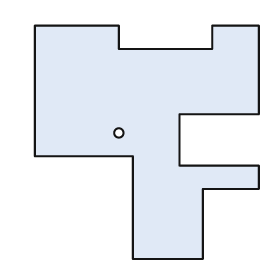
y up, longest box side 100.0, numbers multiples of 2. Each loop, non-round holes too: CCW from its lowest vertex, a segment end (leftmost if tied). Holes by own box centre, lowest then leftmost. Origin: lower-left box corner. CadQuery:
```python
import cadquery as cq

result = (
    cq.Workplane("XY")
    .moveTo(42.0, 0.0)
    .lineTo(72.0, 0.0)
    .lineTo(72.0, 30.0)
    .lineTo(96.0, 30.0)
    .lineTo(96.0, 40.0)
    .lineTo(62.0, 40.0)
    .lineTo(62.0, 62.0)
    .lineTo(96.0, 62.0)
    .lineTo(96.0, 100.0)
    .lineTo(76.0, 100.0)
    .lineTo(76.0, 90.0)
    .lineTo(36.0, 90.0)
    .lineTo(36.0, 100.0)
    .lineTo(0.0, 100.0)
    .lineTo(0.0, 44.0)
    .lineTo(42.0, 44.0)
    .close()
    .moveTo(36.0, 54.0)
    .circle(2.0)
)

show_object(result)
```